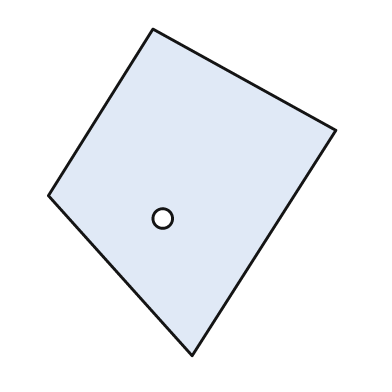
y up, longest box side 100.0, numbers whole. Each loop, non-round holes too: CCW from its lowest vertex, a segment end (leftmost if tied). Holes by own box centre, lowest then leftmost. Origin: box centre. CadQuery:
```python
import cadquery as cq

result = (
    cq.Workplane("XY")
    .moveTo(0.0, -50.0)
    .lineTo(44.0, 19.0)
    .lineTo(-12.0, 50.0)
    .lineTo(-44.0, -1.0)
    .close()
    .moveTo(-9.0, -8.0)
    .circle(3.0)
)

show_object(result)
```